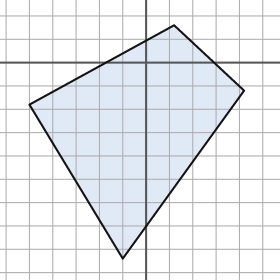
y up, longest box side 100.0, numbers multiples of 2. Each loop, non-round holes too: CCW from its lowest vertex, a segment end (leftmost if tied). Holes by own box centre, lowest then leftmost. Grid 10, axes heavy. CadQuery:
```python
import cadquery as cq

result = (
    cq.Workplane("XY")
    .moveTo(-10.0, -84.0)
    .lineTo(42.0, -12.0)
    .lineTo(12.0, 16.0)
    .lineTo(-50.0, -18.0)
    .close()
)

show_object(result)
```